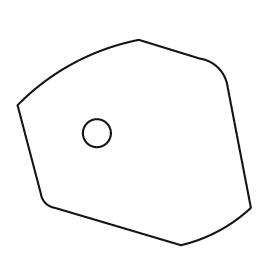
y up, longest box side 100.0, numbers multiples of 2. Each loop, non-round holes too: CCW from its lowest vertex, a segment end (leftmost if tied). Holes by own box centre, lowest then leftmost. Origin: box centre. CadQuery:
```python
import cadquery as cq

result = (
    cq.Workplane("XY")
    .moveTo(20.0, -44.0)
    .threePointArc((36.0, -38.0), (50.0, -28.0))
    .lineTo(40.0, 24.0)
    .threePointArc((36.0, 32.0), (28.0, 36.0))
    .lineTo(2.0, 44.0)
    .threePointArc((-26.0, 34.0), (-50.0, 16.0))
    .lineTo(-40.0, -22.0)
    .threePointArc((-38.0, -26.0), (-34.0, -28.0))
    .close()
    .moveTo(-16.0, 4.0)
    .circle(6.0)
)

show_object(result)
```